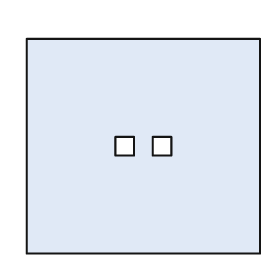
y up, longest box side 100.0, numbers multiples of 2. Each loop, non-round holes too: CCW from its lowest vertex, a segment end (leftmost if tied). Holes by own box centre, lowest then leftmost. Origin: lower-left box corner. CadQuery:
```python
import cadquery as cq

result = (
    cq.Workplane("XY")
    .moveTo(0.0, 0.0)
    .lineTo(100.0, 0.0)
    .lineTo(100.0, 92.0)
    .lineTo(0.0, 92.0)
    .close()
    .moveTo(38.0, 42.0)
    .lineTo(46.0, 42.0)
    .lineTo(46.0, 50.0)
    .lineTo(38.0, 50.0)
    .close()
    .moveTo(54.0, 42.0)
    .lineTo(62.0, 42.0)
    .lineTo(62.0, 50.0)
    .lineTo(54.0, 50.0)
    .close()
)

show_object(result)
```